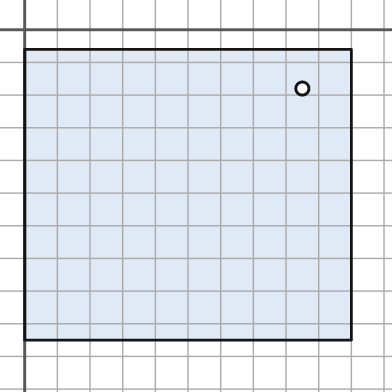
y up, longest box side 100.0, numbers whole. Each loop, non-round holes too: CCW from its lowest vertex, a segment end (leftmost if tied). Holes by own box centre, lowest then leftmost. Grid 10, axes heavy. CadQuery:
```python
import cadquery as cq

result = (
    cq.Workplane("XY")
    .moveTo(0.0, -95.0)
    .lineTo(100.0, -95.0)
    .lineTo(100.0, -6.0)
    .lineTo(0.0, -6.0)
    .close()
    .moveTo(85.0, -18.0)
    .circle(2.0)
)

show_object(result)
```